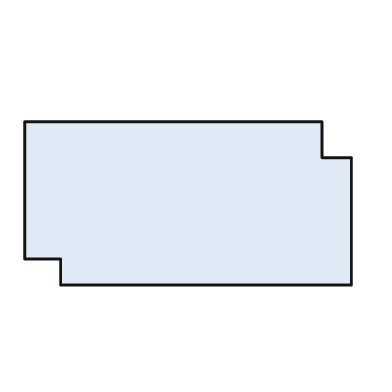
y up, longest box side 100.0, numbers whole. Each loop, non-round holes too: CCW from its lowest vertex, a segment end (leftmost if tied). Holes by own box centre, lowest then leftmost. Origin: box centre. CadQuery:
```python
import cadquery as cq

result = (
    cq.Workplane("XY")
    .moveTo(-39.0, -25.0)
    .lineTo(50.0, -25.0)
    .lineTo(50.0, 14.0)
    .lineTo(41.0, 14.0)
    .lineTo(41.0, 25.0)
    .lineTo(-50.0, 25.0)
    .lineTo(-50.0, -17.0)
    .lineTo(-39.0, -17.0)
    .close()
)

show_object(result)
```